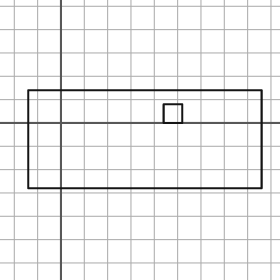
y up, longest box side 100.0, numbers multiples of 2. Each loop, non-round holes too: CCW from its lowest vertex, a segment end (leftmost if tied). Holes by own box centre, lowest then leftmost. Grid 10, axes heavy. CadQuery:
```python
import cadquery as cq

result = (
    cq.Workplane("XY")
    .moveTo(-14.0, -28.0)
    .lineTo(86.0, -28.0)
    .lineTo(86.0, 14.0)
    .lineTo(-14.0, 14.0)
    .close()
    .moveTo(44.0, 0.0)
    .lineTo(52.0, 0.0)
    .lineTo(52.0, 8.0)
    .lineTo(44.0, 8.0)
    .close()
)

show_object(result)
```